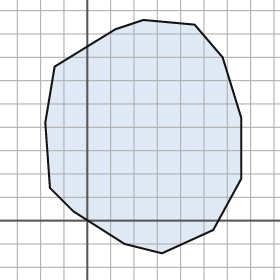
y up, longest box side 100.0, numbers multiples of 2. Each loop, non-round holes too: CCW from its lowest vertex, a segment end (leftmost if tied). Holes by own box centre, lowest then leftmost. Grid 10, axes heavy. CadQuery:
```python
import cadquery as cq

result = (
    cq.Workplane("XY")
    .moveTo(32.0, -14.0)
    .lineTo(54.0, -4.0)
    .lineTo(66.0, 18.0)
    .lineTo(66.0, 44.0)
    .lineTo(58.0, 70.0)
    .lineTo(46.0, 84.0)
    .lineTo(24.0, 86.0)
    .lineTo(12.0, 82.0)
    .lineTo(-14.0, 66.0)
    .lineTo(-18.0, 42.0)
    .lineTo(-16.0, 14.0)
    .lineTo(-6.0, 4.0)
    .lineTo(16.0, -10.0)
    .close()
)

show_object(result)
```